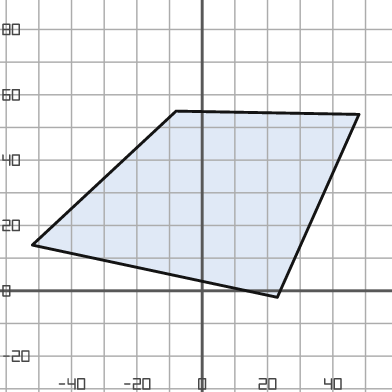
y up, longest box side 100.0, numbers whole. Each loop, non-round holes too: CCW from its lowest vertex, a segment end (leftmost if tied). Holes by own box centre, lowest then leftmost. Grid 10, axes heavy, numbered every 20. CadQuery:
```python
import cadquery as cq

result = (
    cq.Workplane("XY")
    .moveTo(23.0, -2.0)
    .lineTo(48.0, 54.0)
    .lineTo(-8.0, 55.0)
    .lineTo(-52.0, 14.0)
    .close()
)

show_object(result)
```